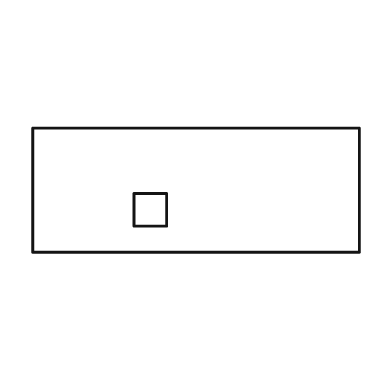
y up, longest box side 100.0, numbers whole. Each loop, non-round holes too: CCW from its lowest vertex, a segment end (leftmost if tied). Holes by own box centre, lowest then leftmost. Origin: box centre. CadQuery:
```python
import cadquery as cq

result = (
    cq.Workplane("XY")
    .moveTo(-50.0, -19.0)
    .lineTo(50.0, -19.0)
    .lineTo(50.0, 19.0)
    .lineTo(-50.0, 19.0)
    .close()
    .moveTo(-19.0, -11.0)
    .lineTo(-9.0, -11.0)
    .lineTo(-9.0, -1.0)
    .lineTo(-19.0, -1.0)
    .close()
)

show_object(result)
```